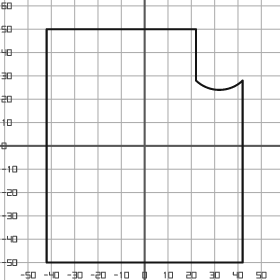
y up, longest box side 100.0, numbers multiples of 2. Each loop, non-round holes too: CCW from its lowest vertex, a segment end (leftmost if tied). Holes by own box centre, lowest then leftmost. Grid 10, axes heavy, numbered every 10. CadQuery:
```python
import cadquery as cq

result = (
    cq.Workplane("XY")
    .moveTo(-42.0, -50.0)
    .lineTo(42.0, -50.0)
    .lineTo(42.0, 28.0)
    .threePointArc((32.0, 24.0), (22.0, 28.0))
    .lineTo(22.0, 50.0)
    .lineTo(-42.0, 50.0)
    .close()
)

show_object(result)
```